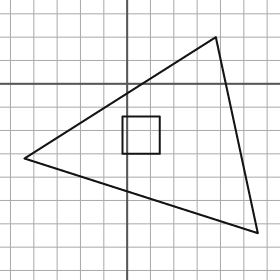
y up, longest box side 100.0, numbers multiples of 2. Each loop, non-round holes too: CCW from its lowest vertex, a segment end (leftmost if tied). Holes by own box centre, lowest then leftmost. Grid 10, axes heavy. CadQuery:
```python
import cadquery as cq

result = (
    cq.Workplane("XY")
    .moveTo(56.0, -64.0)
    .lineTo(38.0, 20.0)
    .lineTo(-44.0, -32.0)
    .close()
    .moveTo(-2.0, -30.0)
    .lineTo(14.0, -30.0)
    .lineTo(14.0, -14.0)
    .lineTo(-2.0, -14.0)
    .close()
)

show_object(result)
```